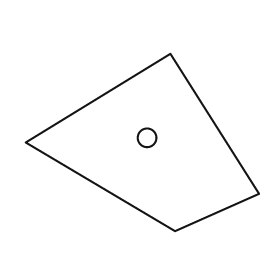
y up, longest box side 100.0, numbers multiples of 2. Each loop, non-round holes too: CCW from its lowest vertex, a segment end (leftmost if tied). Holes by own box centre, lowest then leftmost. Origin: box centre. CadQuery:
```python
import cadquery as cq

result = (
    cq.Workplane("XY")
    .moveTo(14.0, -38.0)
    .lineTo(50.0, -22.0)
    .lineTo(12.0, 38.0)
    .lineTo(-50.0, 0.0)
    .close()
    .moveTo(2.0, 2.0)
    .circle(4.0)
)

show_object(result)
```